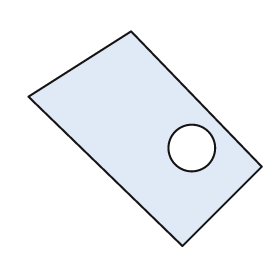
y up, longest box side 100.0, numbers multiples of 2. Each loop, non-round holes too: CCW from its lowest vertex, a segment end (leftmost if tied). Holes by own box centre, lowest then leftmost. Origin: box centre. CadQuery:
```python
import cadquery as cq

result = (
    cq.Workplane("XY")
    .moveTo(16.0, -46.0)
    .lineTo(50.0, -12.0)
    .lineTo(-6.0, 46.0)
    .lineTo(-50.0, 18.0)
    .close()
    .moveTo(20.0, -4.0)
    .circle(10.0)
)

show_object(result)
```